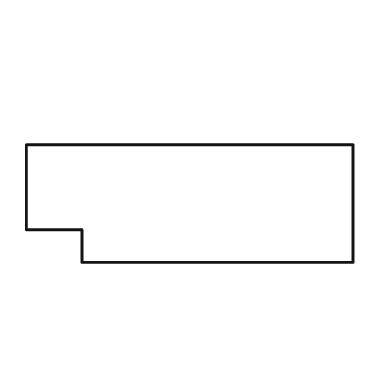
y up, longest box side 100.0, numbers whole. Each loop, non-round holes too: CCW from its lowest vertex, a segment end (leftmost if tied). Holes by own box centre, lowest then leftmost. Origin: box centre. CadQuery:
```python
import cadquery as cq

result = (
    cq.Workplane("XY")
    .moveTo(-33.0, -18.0)
    .lineTo(50.0, -18.0)
    .lineTo(50.0, 18.0)
    .lineTo(-50.0, 18.0)
    .lineTo(-50.0, -8.0)
    .lineTo(-33.0, -8.0)
    .close()
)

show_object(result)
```